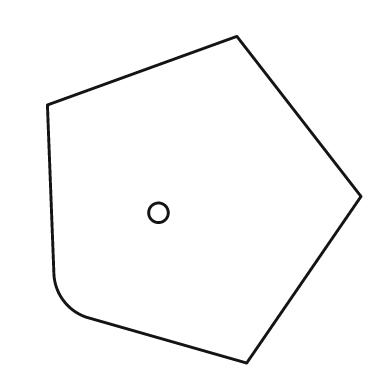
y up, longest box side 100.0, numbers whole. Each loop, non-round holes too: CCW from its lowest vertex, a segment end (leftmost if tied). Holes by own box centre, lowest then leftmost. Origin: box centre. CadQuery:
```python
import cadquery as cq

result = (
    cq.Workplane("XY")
    .moveTo(13.0, -50.0)
    .lineTo(48.0, 1.0)
    .lineTo(10.0, 50.0)
    .lineTo(-48.0, 29.0)
    .lineTo(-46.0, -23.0)
    .threePointArc((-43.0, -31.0), (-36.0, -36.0))
    .close()
    .moveTo(-14.0, -4.0)
    .circle(3.0)
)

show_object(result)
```